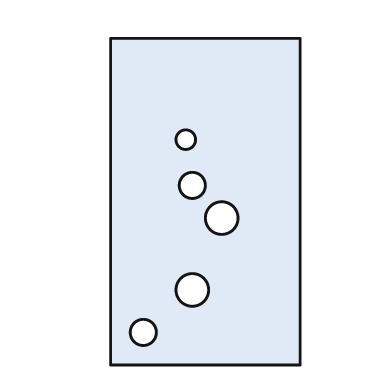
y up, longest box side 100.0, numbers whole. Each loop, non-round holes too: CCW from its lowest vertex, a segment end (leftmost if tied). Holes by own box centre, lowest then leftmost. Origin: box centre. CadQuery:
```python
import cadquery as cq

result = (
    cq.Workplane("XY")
    .moveTo(-29.0, -50.0)
    .lineTo(29.0, -50.0)
    .lineTo(29.0, 50.0)
    .lineTo(-29.0, 50.0)
    .close()
    .moveTo(-19.0, -40.0)
    .circle(4.0)
    .moveTo(-4.0, -27.0)
    .circle(5.0)
    .moveTo(5.0, -5.0)
    .circle(5.0)
    .moveTo(-4.0, 5.0)
    .circle(4.0)
    .moveTo(-6.0, 19.0)
    .circle(3.0)
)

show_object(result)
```